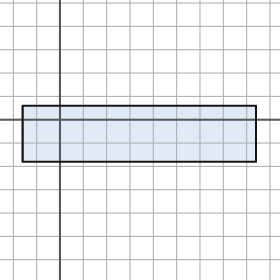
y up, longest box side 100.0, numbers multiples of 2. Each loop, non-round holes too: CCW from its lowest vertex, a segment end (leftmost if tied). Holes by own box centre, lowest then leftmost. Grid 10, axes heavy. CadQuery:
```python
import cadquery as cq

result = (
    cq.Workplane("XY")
    .moveTo(-16.0, -18.0)
    .lineTo(84.0, -18.0)
    .lineTo(84.0, 6.0)
    .lineTo(-16.0, 6.0)
    .close()
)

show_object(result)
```